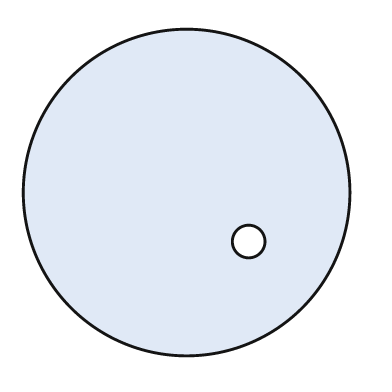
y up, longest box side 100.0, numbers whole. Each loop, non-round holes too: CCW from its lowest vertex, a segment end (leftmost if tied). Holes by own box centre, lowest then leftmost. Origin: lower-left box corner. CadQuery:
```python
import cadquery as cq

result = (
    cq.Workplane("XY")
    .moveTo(50.0, 50.0)
    .circle(50.0)
    .moveTo(69.0, 35.0)
    .circle(5.0)
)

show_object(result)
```